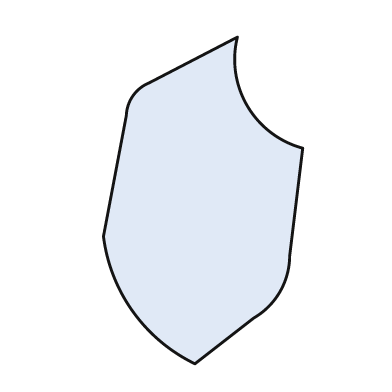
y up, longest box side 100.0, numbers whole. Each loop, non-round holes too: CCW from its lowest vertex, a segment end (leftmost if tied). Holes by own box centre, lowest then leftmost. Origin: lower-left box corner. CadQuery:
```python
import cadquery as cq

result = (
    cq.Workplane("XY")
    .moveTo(28.0, 0.0)
    .lineTo(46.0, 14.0)
    .threePointArc((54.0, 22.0), (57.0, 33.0))
    .lineTo(61.0, 66.0)
    .threePointArc((44.0, 79.0), (41.0, 100.0))
    .lineTo(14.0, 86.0)
    .threePointArc((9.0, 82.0), (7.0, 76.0))
    .lineTo(0.0, 39.0)
    .threePointArc((9.0, 16.0), (28.0, 0.0))
    .close()
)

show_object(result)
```